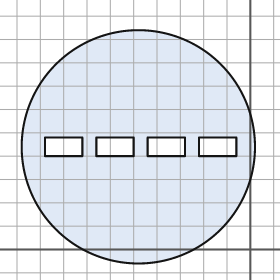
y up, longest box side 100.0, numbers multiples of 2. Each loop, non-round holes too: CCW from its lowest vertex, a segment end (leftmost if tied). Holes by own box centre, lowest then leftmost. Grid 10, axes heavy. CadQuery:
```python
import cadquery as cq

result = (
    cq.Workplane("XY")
    .moveTo(-48.0, 44.0)
    .circle(50.0)
    .moveTo(-88.0, 40.0)
    .lineTo(-72.0, 40.0)
    .lineTo(-72.0, 48.0)
    .lineTo(-88.0, 48.0)
    .close()
    .moveTo(-66.0, 40.0)
    .lineTo(-50.0, 40.0)
    .lineTo(-50.0, 48.0)
    .lineTo(-66.0, 48.0)
    .close()
    .moveTo(-44.0, 40.0)
    .lineTo(-28.0, 40.0)
    .lineTo(-28.0, 48.0)
    .lineTo(-44.0, 48.0)
    .close()
    .moveTo(-22.0, 40.0)
    .lineTo(-6.0, 40.0)
    .lineTo(-6.0, 48.0)
    .lineTo(-22.0, 48.0)
    .close()
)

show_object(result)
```